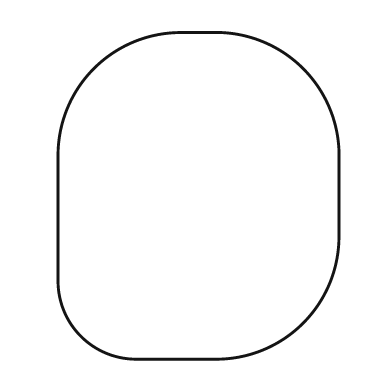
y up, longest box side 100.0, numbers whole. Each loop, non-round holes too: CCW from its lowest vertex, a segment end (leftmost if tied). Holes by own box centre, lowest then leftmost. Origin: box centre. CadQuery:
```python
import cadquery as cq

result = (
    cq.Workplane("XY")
    .moveTo(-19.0, -50.0)
    .lineTo(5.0, -50.0)
    .threePointArc((32.0, -39.0), (43.0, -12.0))
    .lineTo(43.0, 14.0)
    .threePointArc((32.0, 39.0), (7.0, 50.0))
    .lineTo(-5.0, 50.0)
    .threePointArc((-32.0, 39.0), (-43.0, 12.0))
    .lineTo(-43.0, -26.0)
    .threePointArc((-36.0, -43.0), (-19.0, -50.0))
    .close()
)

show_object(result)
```